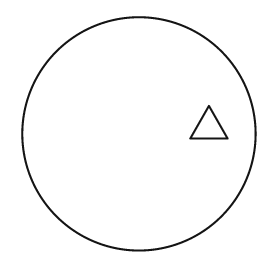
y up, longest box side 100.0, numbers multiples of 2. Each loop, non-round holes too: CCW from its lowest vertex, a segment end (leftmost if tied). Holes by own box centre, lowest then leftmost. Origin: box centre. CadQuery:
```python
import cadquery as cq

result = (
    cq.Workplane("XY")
    .moveTo(0.0, 0.0)
    .circle(50.0)
    .moveTo(22.0, -2.0)
    .lineTo(38.0, -2.0)
    .lineTo(30.0, 12.0)
    .close()
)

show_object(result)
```